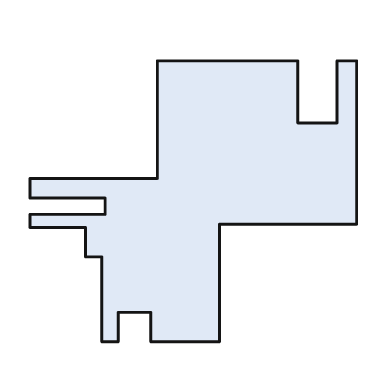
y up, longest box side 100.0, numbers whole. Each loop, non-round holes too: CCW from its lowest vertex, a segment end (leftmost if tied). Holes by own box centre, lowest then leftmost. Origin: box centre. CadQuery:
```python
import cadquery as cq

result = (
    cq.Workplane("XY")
    .moveTo(-28.0, -43.0)
    .lineTo(-23.0, -43.0)
    .lineTo(-23.0, -34.0)
    .lineTo(-13.0, -34.0)
    .lineTo(-13.0, -43.0)
    .lineTo(8.0, -43.0)
    .lineTo(8.0, -7.0)
    .lineTo(50.0, -7.0)
    .lineTo(50.0, 43.0)
    .lineTo(44.0, 43.0)
    .lineTo(44.0, 24.0)
    .lineTo(32.0, 24.0)
    .lineTo(32.0, 43.0)
    .lineTo(-11.0, 43.0)
    .lineTo(-11.0, 7.0)
    .lineTo(-50.0, 7.0)
    .lineTo(-50.0, 1.0)
    .lineTo(-27.0, 1.0)
    .lineTo(-27.0, -4.0)
    .lineTo(-50.0, -4.0)
    .lineTo(-50.0, -8.0)
    .lineTo(-33.0, -8.0)
    .lineTo(-33.0, -17.0)
    .lineTo(-28.0, -17.0)
    .close()
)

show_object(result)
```